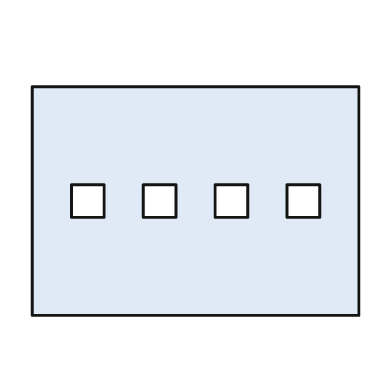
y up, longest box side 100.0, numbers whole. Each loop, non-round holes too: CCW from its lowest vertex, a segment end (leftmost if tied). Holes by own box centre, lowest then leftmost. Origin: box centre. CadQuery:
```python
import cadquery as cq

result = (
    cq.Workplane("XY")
    .moveTo(-50.0, -35.0)
    .lineTo(50.0, -35.0)
    .lineTo(50.0, 35.0)
    .lineTo(-50.0, 35.0)
    .close()
    .moveTo(-38.0, -5.0)
    .lineTo(-28.0, -5.0)
    .lineTo(-28.0, 5.0)
    .lineTo(-38.0, 5.0)
    .close()
    .moveTo(-16.0, -5.0)
    .lineTo(-6.0, -5.0)
    .lineTo(-6.0, 5.0)
    .lineTo(-16.0, 5.0)
    .close()
    .moveTo(6.0, -5.0)
    .lineTo(16.0, -5.0)
    .lineTo(16.0, 5.0)
    .lineTo(6.0, 5.0)
    .close()
    .moveTo(28.0, -5.0)
    .lineTo(38.0, -5.0)
    .lineTo(38.0, 5.0)
    .lineTo(28.0, 5.0)
    .close()
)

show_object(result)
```